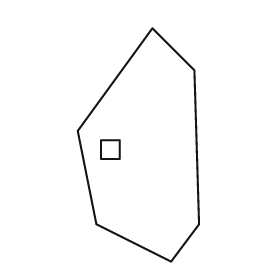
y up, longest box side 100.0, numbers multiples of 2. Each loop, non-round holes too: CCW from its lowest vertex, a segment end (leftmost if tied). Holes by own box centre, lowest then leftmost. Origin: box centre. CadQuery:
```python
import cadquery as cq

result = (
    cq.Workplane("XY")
    .moveTo(14.0, -50.0)
    .lineTo(26.0, -34.0)
    .lineTo(24.0, 32.0)
    .lineTo(6.0, 50.0)
    .lineTo(-26.0, 6.0)
    .lineTo(-18.0, -34.0)
    .close()
    .moveTo(-16.0, -6.0)
    .lineTo(-8.0, -6.0)
    .lineTo(-8.0, 2.0)
    .lineTo(-16.0, 2.0)
    .close()
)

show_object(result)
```